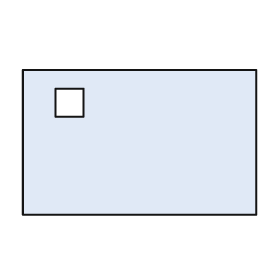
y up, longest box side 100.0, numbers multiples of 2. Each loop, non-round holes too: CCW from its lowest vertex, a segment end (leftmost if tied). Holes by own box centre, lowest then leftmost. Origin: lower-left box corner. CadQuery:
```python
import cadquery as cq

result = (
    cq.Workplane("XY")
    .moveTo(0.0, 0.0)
    .lineTo(100.0, 0.0)
    .lineTo(100.0, 62.0)
    .lineTo(0.0, 62.0)
    .close()
    .moveTo(14.0, 42.0)
    .lineTo(26.0, 42.0)
    .lineTo(26.0, 54.0)
    .lineTo(14.0, 54.0)
    .close()
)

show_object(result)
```